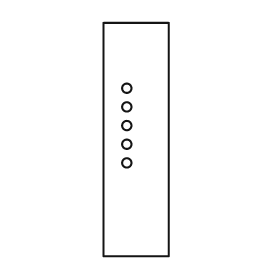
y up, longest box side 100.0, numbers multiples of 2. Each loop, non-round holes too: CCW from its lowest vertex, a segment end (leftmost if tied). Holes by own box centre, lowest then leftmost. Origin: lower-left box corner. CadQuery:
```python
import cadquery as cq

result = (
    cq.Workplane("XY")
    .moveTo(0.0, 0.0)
    .lineTo(28.0, 0.0)
    .lineTo(28.0, 100.0)
    .lineTo(0.0, 100.0)
    .close()
    .moveTo(10.0, 40.0)
    .circle(2.0)
    .moveTo(10.0, 48.0)
    .circle(2.0)
    .moveTo(10.0, 56.0)
    .circle(2.0)
    .moveTo(10.0, 64.0)
    .circle(2.0)
    .moveTo(10.0, 72.0)
    .circle(2.0)
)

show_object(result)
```